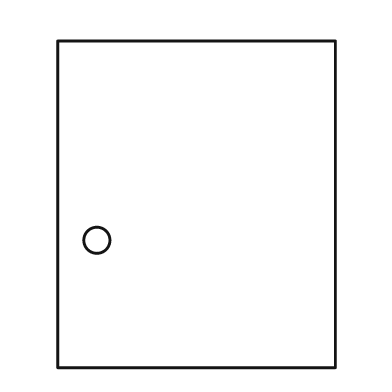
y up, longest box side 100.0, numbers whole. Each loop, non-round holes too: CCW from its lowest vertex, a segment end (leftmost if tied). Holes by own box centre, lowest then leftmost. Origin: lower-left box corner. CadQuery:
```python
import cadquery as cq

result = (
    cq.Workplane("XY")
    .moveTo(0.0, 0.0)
    .lineTo(85.0, 0.0)
    .lineTo(85.0, 100.0)
    .lineTo(0.0, 100.0)
    .close()
    .moveTo(12.0, 39.0)
    .circle(4.0)
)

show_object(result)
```